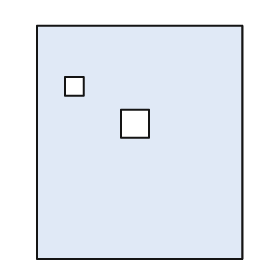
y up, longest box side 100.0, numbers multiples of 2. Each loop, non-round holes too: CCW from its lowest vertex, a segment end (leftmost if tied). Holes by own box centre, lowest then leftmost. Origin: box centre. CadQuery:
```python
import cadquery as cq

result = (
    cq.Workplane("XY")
    .moveTo(-44.0, -50.0)
    .lineTo(44.0, -50.0)
    .lineTo(44.0, 50.0)
    .lineTo(-44.0, 50.0)
    .close()
    .moveTo(-8.0, 2.0)
    .lineTo(4.0, 2.0)
    .lineTo(4.0, 14.0)
    .lineTo(-8.0, 14.0)
    .close()
    .moveTo(-32.0, 20.0)
    .lineTo(-24.0, 20.0)
    .lineTo(-24.0, 28.0)
    .lineTo(-32.0, 28.0)
    .close()
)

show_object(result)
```